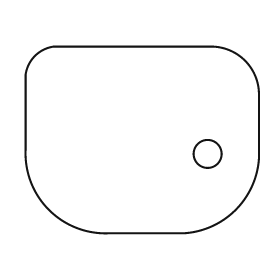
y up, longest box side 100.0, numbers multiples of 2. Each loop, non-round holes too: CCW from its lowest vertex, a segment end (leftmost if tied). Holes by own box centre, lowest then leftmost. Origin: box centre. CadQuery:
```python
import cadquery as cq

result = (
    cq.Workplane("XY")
    .moveTo(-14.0, -40.0)
    .lineTo(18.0, -40.0)
    .threePointArc((40.0, -30.0), (50.0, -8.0))
    .lineTo(50.0, 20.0)
    .threePointArc((44.0, 34.0), (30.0, 40.0))
    .lineTo(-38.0, 40.0)
    .threePointArc((-46.0, 36.0), (-50.0, 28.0))
    .lineTo(-50.0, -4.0)
    .threePointArc((-40.0, -30.0), (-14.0, -40.0))
    .close()
    .moveTo(28.0, -6.0)
    .circle(6.0)
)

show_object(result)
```